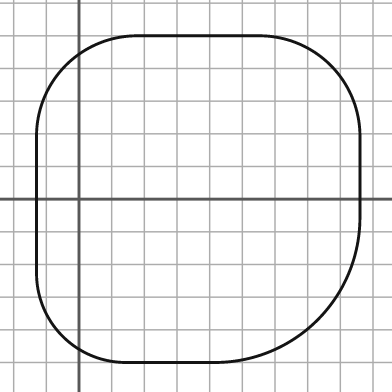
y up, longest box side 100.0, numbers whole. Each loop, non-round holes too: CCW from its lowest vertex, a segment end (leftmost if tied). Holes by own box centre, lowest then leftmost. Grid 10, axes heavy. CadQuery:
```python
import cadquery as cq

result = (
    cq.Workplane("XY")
    .moveTo(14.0, -50.0)
    .lineTo(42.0, -50.0)
    .threePointArc((73.0, -37.0), (86.0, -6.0))
    .lineTo(86.0, 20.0)
    .threePointArc((77.0, 41.0), (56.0, 50.0))
    .lineTo(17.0, 50.0)
    .threePointArc((-4.0, 41.0), (-13.0, 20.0))
    .lineTo(-13.0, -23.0)
    .threePointArc((-5.0, -42.0), (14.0, -50.0))
    .close()
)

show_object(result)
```